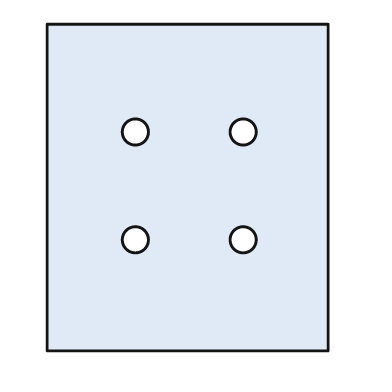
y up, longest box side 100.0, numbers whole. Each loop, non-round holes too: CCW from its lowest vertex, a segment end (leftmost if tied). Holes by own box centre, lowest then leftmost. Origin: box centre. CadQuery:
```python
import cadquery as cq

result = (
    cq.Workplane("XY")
    .moveTo(-43.0, -50.0)
    .lineTo(43.0, -50.0)
    .lineTo(43.0, 50.0)
    .lineTo(-43.0, 50.0)
    .close()
    .moveTo(-16.0, -16.0)
    .circle(4.0)
    .moveTo(17.0, -16.0)
    .circle(4.0)
    .moveTo(-16.0, 17.0)
    .circle(4.0)
    .moveTo(17.0, 17.0)
    .circle(4.0)
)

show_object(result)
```